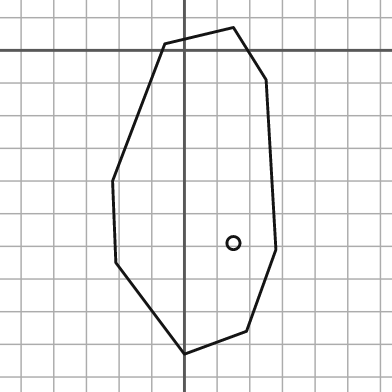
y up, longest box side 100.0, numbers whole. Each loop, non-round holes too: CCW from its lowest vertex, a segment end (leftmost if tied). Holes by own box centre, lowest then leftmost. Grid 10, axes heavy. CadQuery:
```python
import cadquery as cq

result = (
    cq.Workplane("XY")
    .moveTo(0.0, -93.0)
    .lineTo(19.0, -86.0)
    .lineTo(28.0, -61.0)
    .lineTo(25.0, -9.0)
    .lineTo(15.0, 7.0)
    .lineTo(-6.0, 2.0)
    .lineTo(-22.0, -40.0)
    .lineTo(-21.0, -65.0)
    .close()
    .moveTo(15.0, -59.0)
    .circle(2.0)
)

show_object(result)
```